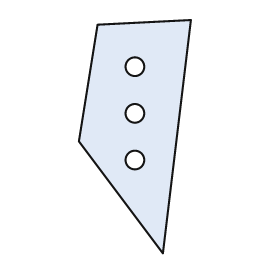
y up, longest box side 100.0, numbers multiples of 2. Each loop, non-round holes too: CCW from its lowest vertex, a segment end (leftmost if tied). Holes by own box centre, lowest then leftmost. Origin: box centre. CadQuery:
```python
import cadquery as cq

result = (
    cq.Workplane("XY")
    .moveTo(12.0, -50.0)
    .lineTo(24.0, 50.0)
    .lineTo(-16.0, 48.0)
    .lineTo(-24.0, -2.0)
    .close()
    .moveTo(0.0, -10.0)
    .circle(4.0)
    .moveTo(0.0, 10.0)
    .circle(4.0)
    .moveTo(0.0, 30.0)
    .circle(4.0)
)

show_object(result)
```